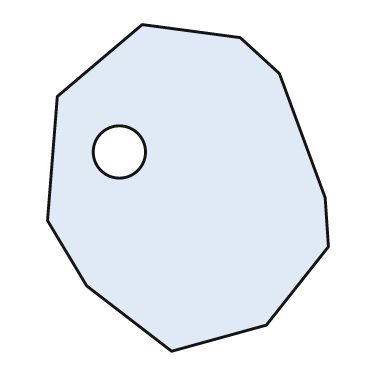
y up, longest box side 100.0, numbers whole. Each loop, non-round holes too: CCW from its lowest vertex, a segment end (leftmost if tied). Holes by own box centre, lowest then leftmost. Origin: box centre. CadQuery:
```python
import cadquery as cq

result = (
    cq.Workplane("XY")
    .moveTo(-5.0, -50.0)
    .lineTo(24.0, -42.0)
    .lineTo(43.0, -18.0)
    .lineTo(42.0, -3.0)
    .lineTo(28.0, 35.0)
    .lineTo(16.0, 46.0)
    .lineTo(-14.0, 50.0)
    .lineTo(-40.0, 28.0)
    .lineTo(-43.0, -10.0)
    .lineTo(-31.0, -30.0)
    .close()
    .moveTo(-21.0, 11.0)
    .circle(8.0)
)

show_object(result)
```